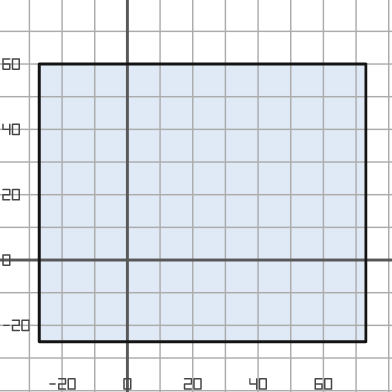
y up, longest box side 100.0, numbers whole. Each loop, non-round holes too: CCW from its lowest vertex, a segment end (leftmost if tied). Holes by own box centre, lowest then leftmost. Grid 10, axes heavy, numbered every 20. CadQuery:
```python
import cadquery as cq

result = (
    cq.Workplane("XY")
    .moveTo(-27.0, -25.0)
    .lineTo(73.0, -25.0)
    .lineTo(73.0, 60.0)
    .lineTo(-27.0, 60.0)
    .close()
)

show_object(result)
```